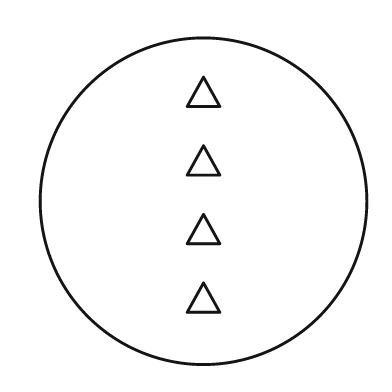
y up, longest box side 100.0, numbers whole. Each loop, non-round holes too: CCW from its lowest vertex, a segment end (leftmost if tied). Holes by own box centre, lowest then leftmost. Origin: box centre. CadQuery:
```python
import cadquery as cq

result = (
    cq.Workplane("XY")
    .moveTo(0.0, 0.0)
    .circle(50.0)
    .moveTo(-5.0, -34.0)
    .lineTo(5.0, -34.0)
    .lineTo(0.0, -25.0)
    .close()
    .moveTo(-5.0, -13.0)
    .lineTo(5.0, -13.0)
    .lineTo(0.0, -4.0)
    .close()
    .moveTo(-5.0, 8.0)
    .lineTo(5.0, 8.0)
    .lineTo(0.0, 17.0)
    .close()
    .moveTo(-5.0, 29.0)
    .lineTo(5.0, 29.0)
    .lineTo(0.0, 38.0)
    .close()
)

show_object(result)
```